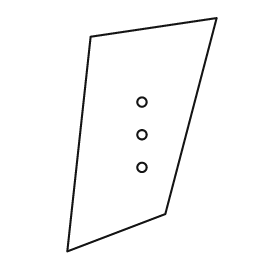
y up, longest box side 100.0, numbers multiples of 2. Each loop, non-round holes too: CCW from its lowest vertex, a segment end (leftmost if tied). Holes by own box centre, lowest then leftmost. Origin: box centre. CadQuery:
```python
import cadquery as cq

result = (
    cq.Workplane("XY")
    .moveTo(-32.0, -50.0)
    .lineTo(10.0, -34.0)
    .lineTo(32.0, 50.0)
    .lineTo(-22.0, 42.0)
    .close()
    .moveTo(0.0, -14.0)
    .circle(2.0)
    .moveTo(0.0, 0.0)
    .circle(2.0)
    .moveTo(0.0, 14.0)
    .circle(2.0)
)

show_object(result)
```